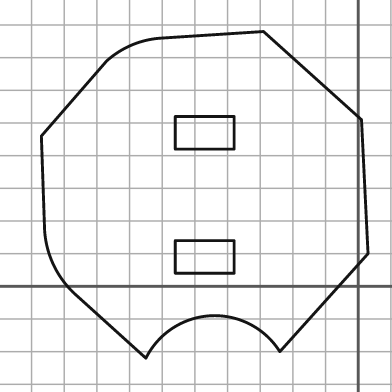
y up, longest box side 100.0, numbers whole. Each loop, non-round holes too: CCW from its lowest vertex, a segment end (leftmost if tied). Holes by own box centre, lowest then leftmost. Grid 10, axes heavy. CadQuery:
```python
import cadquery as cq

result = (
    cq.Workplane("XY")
    .moveTo(-65.0, -22.0)
    .threePointArc((-45.0, -9.0), (-24.0, -20.0))
    .lineTo(3.0, 10.0)
    .lineTo(1.0, 51.0)
    .lineTo(-29.0, 78.0)
    .lineTo(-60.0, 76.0)
    .threePointArc((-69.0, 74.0), (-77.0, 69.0))
    .lineTo(-97.0, 46.0)
    .lineTo(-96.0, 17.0)
    .threePointArc((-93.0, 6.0), (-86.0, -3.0))
    .close()
    .moveTo(-56.0, 4.0)
    .lineTo(-38.0, 4.0)
    .lineTo(-38.0, 14.0)
    .lineTo(-56.0, 14.0)
    .close()
    .moveTo(-56.0, 42.0)
    .lineTo(-38.0, 42.0)
    .lineTo(-38.0, 52.0)
    .lineTo(-56.0, 52.0)
    .close()
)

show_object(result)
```